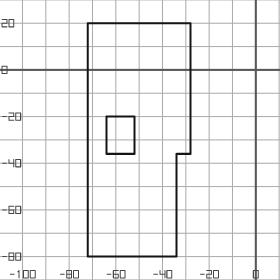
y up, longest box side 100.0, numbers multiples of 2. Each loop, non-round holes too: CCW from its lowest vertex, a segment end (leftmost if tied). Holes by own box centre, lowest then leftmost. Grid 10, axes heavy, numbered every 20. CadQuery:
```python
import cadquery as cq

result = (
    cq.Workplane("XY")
    .moveTo(-72.0, -80.0)
    .lineTo(-34.0, -80.0)
    .lineTo(-34.0, -36.0)
    .lineTo(-28.0, -36.0)
    .lineTo(-28.0, 20.0)
    .lineTo(-72.0, 20.0)
    .close()
    .moveTo(-64.0, -36.0)
    .lineTo(-52.0, -36.0)
    .lineTo(-52.0, -20.0)
    .lineTo(-64.0, -20.0)
    .close()
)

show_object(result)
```